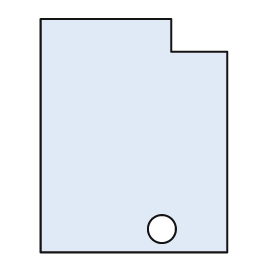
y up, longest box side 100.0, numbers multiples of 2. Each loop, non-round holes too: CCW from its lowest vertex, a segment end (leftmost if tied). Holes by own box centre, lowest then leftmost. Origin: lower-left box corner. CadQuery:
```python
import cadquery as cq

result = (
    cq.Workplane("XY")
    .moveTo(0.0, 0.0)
    .lineTo(80.0, 0.0)
    .lineTo(80.0, 86.0)
    .lineTo(56.0, 86.0)
    .lineTo(56.0, 100.0)
    .lineTo(0.0, 100.0)
    .close()
    .moveTo(52.0, 10.0)
    .circle(6.0)
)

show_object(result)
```